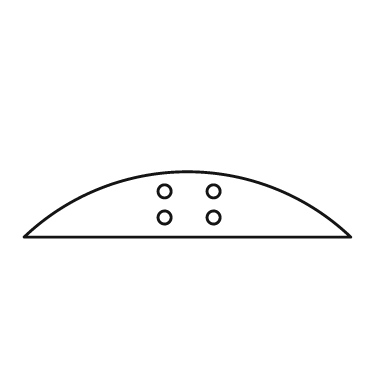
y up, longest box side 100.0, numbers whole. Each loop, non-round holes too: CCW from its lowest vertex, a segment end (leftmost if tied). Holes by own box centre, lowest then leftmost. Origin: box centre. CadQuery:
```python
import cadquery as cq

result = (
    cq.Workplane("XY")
    .moveTo(-50.0, -10.0)
    .lineTo(50.0, -10.0)
    .threePointArc((0.0, 10.0), (-50.0, -10.0))
    .close()
    .moveTo(-7.0, -4.0)
    .circle(2.0)
    .moveTo(8.0, -4.0)
    .circle(2.0)
    .moveTo(-7.0, 4.0)
    .circle(2.0)
    .moveTo(8.0, 4.0)
    .circle(2.0)
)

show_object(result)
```